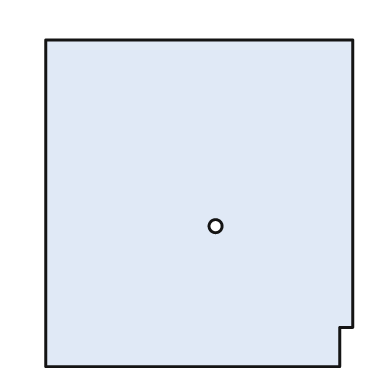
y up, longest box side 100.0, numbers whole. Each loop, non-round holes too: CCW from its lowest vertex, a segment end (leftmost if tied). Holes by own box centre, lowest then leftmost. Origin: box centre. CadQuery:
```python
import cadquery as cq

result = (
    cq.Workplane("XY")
    .moveTo(-47.0, -50.0)
    .lineTo(43.0, -50.0)
    .lineTo(43.0, -38.0)
    .lineTo(47.0, -38.0)
    .lineTo(47.0, 50.0)
    .lineTo(-47.0, 50.0)
    .close()
    .moveTo(5.0, -7.0)
    .circle(2.0)
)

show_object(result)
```